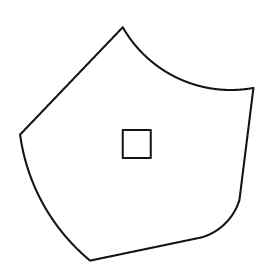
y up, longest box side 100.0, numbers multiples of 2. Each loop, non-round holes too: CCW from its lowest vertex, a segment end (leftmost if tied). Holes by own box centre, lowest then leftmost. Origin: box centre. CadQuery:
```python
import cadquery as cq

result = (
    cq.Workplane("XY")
    .moveTo(-20.0, -50.0)
    .lineTo(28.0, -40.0)
    .threePointArc((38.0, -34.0), (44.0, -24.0))
    .lineTo(50.0, 24.0)
    .threePointArc((18.0, 28.0), (-6.0, 50.0))
    .lineTo(-50.0, 4.0)
    .threePointArc((-40.0, -26.0), (-20.0, -50.0))
    .close()
    .moveTo(-6.0, -6.0)
    .lineTo(6.0, -6.0)
    .lineTo(6.0, 6.0)
    .lineTo(-6.0, 6.0)
    .close()
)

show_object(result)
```